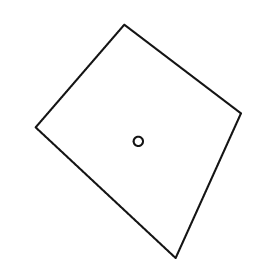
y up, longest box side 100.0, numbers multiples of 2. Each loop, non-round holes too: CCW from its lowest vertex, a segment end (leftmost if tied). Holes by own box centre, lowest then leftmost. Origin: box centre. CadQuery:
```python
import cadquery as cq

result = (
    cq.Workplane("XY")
    .moveTo(16.0, -50.0)
    .lineTo(44.0, 12.0)
    .lineTo(-6.0, 50.0)
    .lineTo(-44.0, 6.0)
    .close()
    .moveTo(0.0, 0.0)
    .circle(2.0)
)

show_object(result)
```